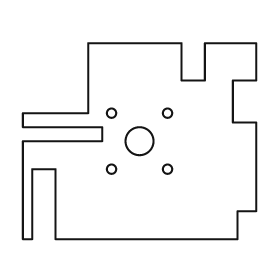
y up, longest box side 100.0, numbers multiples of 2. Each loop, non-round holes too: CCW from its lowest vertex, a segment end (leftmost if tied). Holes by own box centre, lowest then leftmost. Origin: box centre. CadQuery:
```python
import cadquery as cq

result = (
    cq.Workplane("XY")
    .moveTo(-50.0, -42.0)
    .lineTo(-46.0, -42.0)
    .lineTo(-46.0, -12.0)
    .lineTo(-36.0, -12.0)
    .lineTo(-36.0, -42.0)
    .lineTo(42.0, -42.0)
    .lineTo(42.0, -30.0)
    .lineTo(50.0, -30.0)
    .lineTo(50.0, 8.0)
    .lineTo(40.0, 8.0)
    .lineTo(40.0, 26.0)
    .lineTo(50.0, 26.0)
    .lineTo(50.0, 42.0)
    .lineTo(28.0, 42.0)
    .lineTo(28.0, 26.0)
    .lineTo(18.0, 26.0)
    .lineTo(18.0, 42.0)
    .lineTo(-22.0, 42.0)
    .lineTo(-22.0, 12.0)
    .lineTo(-50.0, 12.0)
    .lineTo(-50.0, 6.0)
    .lineTo(-16.0, 6.0)
    .lineTo(-16.0, 0.0)
    .lineTo(-50.0, 0.0)
    .close()
    .moveTo(-12.0, -12.0)
    .circle(2.0)
    .moveTo(12.0, -12.0)
    .circle(2.0)
    .moveTo(0.0, 0.0)
    .circle(6.0)
    .moveTo(-12.0, 12.0)
    .circle(2.0)
    .moveTo(12.0, 12.0)
    .circle(2.0)
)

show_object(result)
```